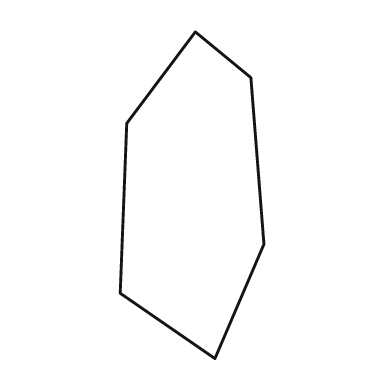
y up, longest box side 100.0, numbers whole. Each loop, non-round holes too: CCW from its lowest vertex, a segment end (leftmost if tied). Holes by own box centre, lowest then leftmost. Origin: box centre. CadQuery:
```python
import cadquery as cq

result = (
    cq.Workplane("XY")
    .moveTo(7.0, -50.0)
    .lineTo(22.0, -15.0)
    .lineTo(18.0, 36.0)
    .lineTo(1.0, 50.0)
    .lineTo(-20.0, 22.0)
    .lineTo(-22.0, -30.0)
    .close()
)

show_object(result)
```